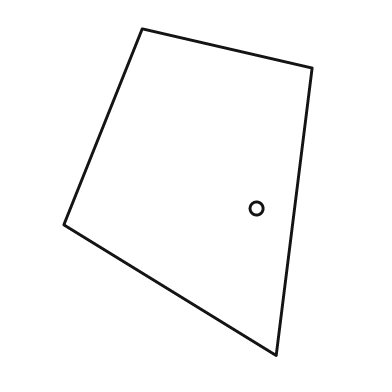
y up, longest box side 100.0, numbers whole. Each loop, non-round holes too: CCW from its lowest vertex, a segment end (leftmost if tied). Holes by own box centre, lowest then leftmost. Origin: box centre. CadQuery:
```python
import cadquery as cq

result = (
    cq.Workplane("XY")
    .moveTo(27.0, -50.0)
    .lineTo(38.0, 38.0)
    .lineTo(-14.0, 50.0)
    .lineTo(-38.0, -10.0)
    .close()
    .moveTo(21.0, -5.0)
    .circle(2.0)
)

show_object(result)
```